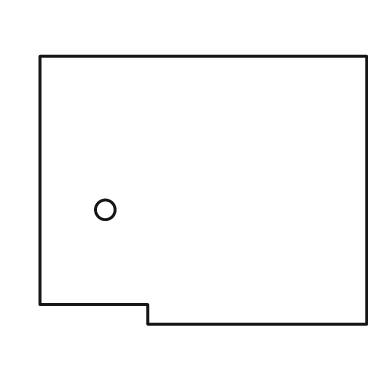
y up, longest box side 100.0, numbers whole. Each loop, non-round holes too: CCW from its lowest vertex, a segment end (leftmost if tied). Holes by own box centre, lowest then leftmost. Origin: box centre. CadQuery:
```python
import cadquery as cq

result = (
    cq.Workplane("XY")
    .moveTo(-17.0, -41.0)
    .lineTo(50.0, -41.0)
    .lineTo(50.0, 41.0)
    .lineTo(-50.0, 41.0)
    .lineTo(-50.0, -35.0)
    .lineTo(-17.0, -35.0)
    .close()
    .moveTo(-30.0, -6.0)
    .circle(3.0)
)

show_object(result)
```